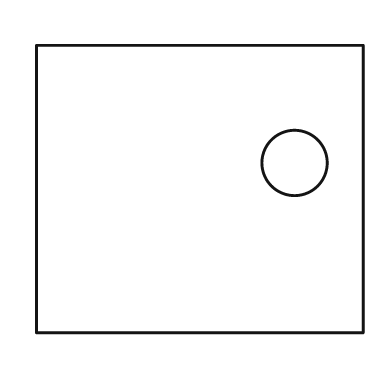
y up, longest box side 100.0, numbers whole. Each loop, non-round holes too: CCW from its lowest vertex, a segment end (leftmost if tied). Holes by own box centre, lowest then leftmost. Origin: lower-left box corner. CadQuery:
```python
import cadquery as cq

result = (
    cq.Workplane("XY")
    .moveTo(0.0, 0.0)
    .lineTo(100.0, 0.0)
    .lineTo(100.0, 88.0)
    .lineTo(0.0, 88.0)
    .close()
    .moveTo(79.0, 52.0)
    .circle(10.0)
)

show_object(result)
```